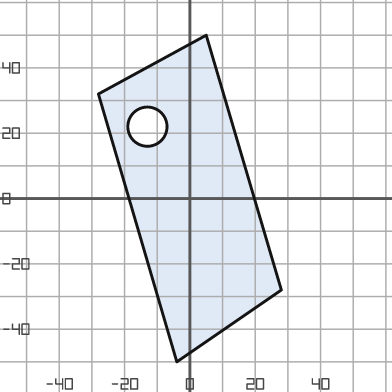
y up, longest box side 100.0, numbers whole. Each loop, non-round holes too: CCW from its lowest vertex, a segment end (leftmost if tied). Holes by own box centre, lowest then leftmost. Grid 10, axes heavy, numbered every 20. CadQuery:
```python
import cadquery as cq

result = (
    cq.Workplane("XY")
    .moveTo(-4.0, -50.0)
    .lineTo(28.0, -28.0)
    .lineTo(5.0, 50.0)
    .lineTo(-28.0, 32.0)
    .close()
    .moveTo(-13.0, 22.0)
    .circle(6.0)
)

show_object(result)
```